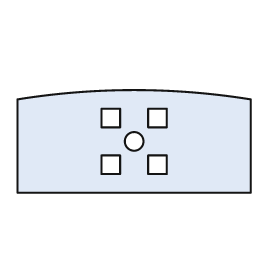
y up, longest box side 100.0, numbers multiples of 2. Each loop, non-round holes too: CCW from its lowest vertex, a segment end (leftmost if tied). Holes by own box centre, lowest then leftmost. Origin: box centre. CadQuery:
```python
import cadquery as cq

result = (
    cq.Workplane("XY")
    .moveTo(-50.0, -22.0)
    .lineTo(50.0, -22.0)
    .lineTo(50.0, 18.0)
    .threePointArc((0.0, 22.0), (-50.0, 18.0))
    .close()
    .moveTo(-14.0, -14.0)
    .lineTo(-6.0, -14.0)
    .lineTo(-6.0, -6.0)
    .lineTo(-14.0, -6.0)
    .close()
    .moveTo(6.0, -14.0)
    .lineTo(14.0, -14.0)
    .lineTo(14.0, -6.0)
    .lineTo(6.0, -6.0)
    .close()
    .moveTo(0.0, 0.0)
    .circle(4.0)
    .moveTo(-14.0, 6.0)
    .lineTo(-6.0, 6.0)
    .lineTo(-6.0, 14.0)
    .lineTo(-14.0, 14.0)
    .close()
    .moveTo(6.0, 6.0)
    .lineTo(14.0, 6.0)
    .lineTo(14.0, 14.0)
    .lineTo(6.0, 14.0)
    .close()
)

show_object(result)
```